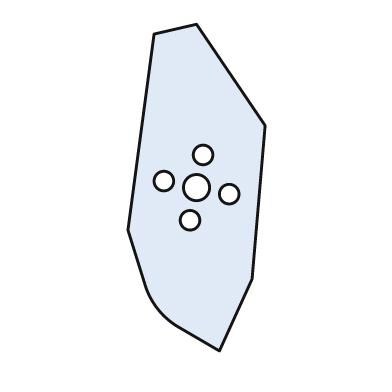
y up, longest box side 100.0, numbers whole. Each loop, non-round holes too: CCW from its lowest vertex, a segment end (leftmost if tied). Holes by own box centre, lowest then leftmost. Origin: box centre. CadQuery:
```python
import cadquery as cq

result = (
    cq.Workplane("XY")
    .moveTo(7.0, -50.0)
    .lineTo(17.0, -28.0)
    .lineTo(21.0, 19.0)
    .lineTo(0.0, 50.0)
    .lineTo(-13.0, 47.0)
    .lineTo(-21.0, -13.0)
    .lineTo(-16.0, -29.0)
    .threePointArc((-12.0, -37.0), (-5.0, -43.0))
    .close()
    .moveTo(-2.0, -10.0)
    .circle(3.0)
    .moveTo(10.0, -2.0)
    .circle(3.0)
    .moveTo(0.0, 0.0)
    .circle(4.0)
    .moveTo(-10.0, 2.0)
    .circle(3.0)
    .moveTo(2.0, 10.0)
    .circle(3.0)
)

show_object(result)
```